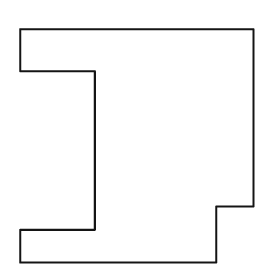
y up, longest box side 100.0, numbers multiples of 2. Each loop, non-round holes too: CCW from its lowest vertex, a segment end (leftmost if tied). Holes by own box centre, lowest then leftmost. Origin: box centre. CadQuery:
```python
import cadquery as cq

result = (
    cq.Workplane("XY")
    .moveTo(-50.0, -50.0)
    .lineTo(34.0, -50.0)
    .lineTo(34.0, -26.0)
    .lineTo(50.0, -26.0)
    .lineTo(50.0, 50.0)
    .lineTo(-50.0, 50.0)
    .lineTo(-50.0, 32.0)
    .lineTo(-18.0, 32.0)
    .lineTo(-18.0, -36.0)
    .lineTo(-50.0, -36.0)
    .close()
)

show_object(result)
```